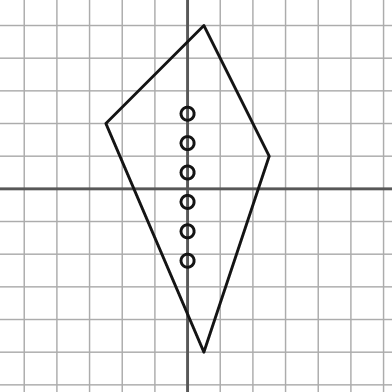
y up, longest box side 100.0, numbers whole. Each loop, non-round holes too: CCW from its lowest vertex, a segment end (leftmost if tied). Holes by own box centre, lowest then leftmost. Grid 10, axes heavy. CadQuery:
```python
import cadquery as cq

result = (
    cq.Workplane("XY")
    .moveTo(5.0, -50.0)
    .lineTo(25.0, 10.0)
    .lineTo(5.0, 50.0)
    .lineTo(-25.0, 20.0)
    .close()
    .moveTo(0.0, -22.0)
    .circle(2.0)
    .moveTo(0.0, -13.0)
    .circle(2.0)
    .moveTo(0.0, -4.0)
    .circle(2.0)
    .moveTo(0.0, 5.0)
    .circle(2.0)
    .moveTo(0.0, 14.0)
    .circle(2.0)
    .moveTo(0.0, 23.0)
    .circle(2.0)
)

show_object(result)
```